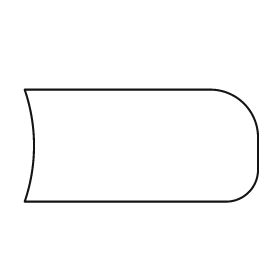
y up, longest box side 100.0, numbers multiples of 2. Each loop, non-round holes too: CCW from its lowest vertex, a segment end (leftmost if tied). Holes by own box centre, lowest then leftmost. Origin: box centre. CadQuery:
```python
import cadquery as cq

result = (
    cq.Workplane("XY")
    .moveTo(-50.0, -24.0)
    .lineTo(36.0, -24.0)
    .threePointArc((46.0, -20.0), (50.0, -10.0))
    .lineTo(50.0, 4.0)
    .threePointArc((44.0, 18.0), (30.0, 24.0))
    .lineTo(-50.0, 24.0)
    .threePointArc((-46.0, 0.0), (-50.0, -24.0))
    .close()
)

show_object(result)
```